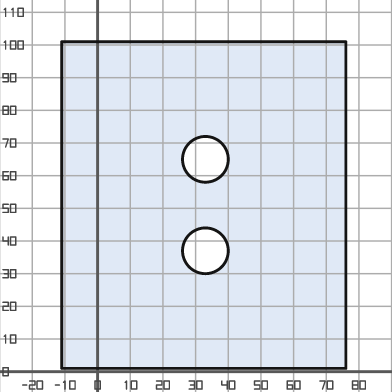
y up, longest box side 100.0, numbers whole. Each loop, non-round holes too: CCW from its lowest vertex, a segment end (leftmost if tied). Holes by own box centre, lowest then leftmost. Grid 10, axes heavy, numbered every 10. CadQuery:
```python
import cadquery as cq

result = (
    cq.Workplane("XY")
    .moveTo(-11.0, 1.0)
    .lineTo(76.0, 1.0)
    .lineTo(76.0, 101.0)
    .lineTo(-11.0, 101.0)
    .close()
    .moveTo(33.0, 37.0)
    .circle(7.0)
    .moveTo(33.0, 65.0)
    .circle(7.0)
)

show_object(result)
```